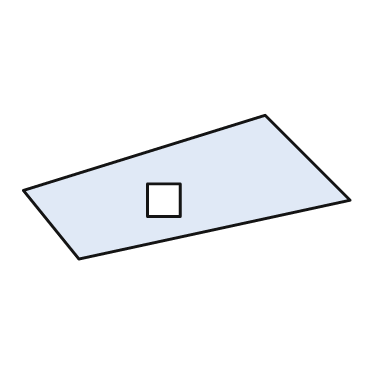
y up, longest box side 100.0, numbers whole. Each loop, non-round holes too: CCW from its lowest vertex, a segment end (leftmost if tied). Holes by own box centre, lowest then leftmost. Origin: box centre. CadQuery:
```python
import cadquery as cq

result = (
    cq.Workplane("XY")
    .moveTo(-33.0, -22.0)
    .lineTo(50.0, -4.0)
    .lineTo(24.0, 22.0)
    .lineTo(-50.0, -1.0)
    .close()
    .moveTo(-12.0, -9.0)
    .lineTo(-2.0, -9.0)
    .lineTo(-2.0, 1.0)
    .lineTo(-12.0, 1.0)
    .close()
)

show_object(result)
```